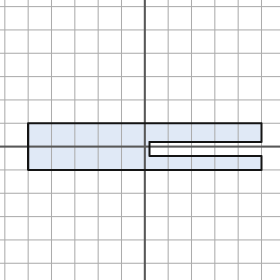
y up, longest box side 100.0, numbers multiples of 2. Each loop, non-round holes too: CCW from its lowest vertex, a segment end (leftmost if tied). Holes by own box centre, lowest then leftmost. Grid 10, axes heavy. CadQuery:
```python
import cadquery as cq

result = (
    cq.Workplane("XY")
    .moveTo(-50.0, -10.0)
    .lineTo(50.0, -10.0)
    .lineTo(50.0, -4.0)
    .lineTo(2.0, -4.0)
    .lineTo(2.0, 2.0)
    .lineTo(50.0, 2.0)
    .lineTo(50.0, 10.0)
    .lineTo(-50.0, 10.0)
    .close()
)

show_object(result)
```